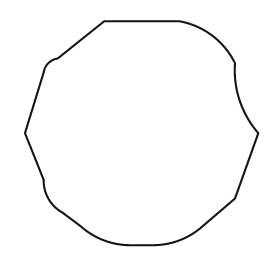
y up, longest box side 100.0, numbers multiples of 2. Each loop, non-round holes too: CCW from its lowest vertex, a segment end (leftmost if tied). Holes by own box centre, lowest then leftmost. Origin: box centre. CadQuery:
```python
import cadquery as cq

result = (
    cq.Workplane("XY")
    .moveTo(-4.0, -48.0)
    .lineTo(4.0, -48.0)
    .threePointArc((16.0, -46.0), (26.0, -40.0))
    .lineTo(40.0, -28.0)
    .lineTo(50.0, 0.0)
    .threePointArc((42.0, 14.0), (40.0, 30.0))
    .threePointArc((30.0, 42.0), (16.0, 48.0))
    .lineTo(-16.0, 48.0)
    .lineTo(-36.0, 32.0)
    .threePointArc((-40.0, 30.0), (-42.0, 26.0))
    .lineTo(-50.0, 0.0)
    .lineTo(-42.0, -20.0)
    .threePointArc((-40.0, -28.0), (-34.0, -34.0))
    .lineTo(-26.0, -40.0)
    .threePointArc((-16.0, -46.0), (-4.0, -48.0))
    .close()
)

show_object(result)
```